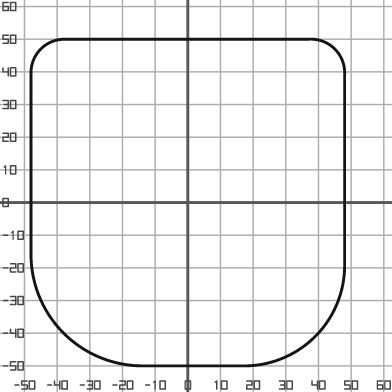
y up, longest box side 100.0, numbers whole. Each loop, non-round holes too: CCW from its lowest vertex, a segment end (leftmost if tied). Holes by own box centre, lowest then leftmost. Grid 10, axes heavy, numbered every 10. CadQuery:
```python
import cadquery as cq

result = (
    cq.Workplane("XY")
    .moveTo(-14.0, -50.0)
    .lineTo(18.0, -50.0)
    .threePointArc((39.0, -41.0), (48.0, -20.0))
    .lineTo(48.0, 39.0)
    .threePointArc((45.0, 47.0), (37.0, 50.0))
    .lineTo(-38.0, 50.0)
    .threePointArc((-45.0, 47.0), (-48.0, 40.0))
    .lineTo(-48.0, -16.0)
    .threePointArc((-38.0, -40.0), (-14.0, -50.0))
    .close()
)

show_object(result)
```